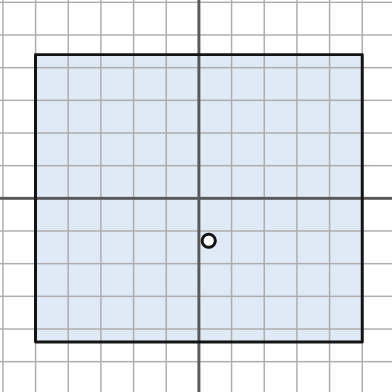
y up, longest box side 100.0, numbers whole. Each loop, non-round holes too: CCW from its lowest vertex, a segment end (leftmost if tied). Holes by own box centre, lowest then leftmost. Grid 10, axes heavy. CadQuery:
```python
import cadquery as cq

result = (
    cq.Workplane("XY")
    .moveTo(-50.0, -44.0)
    .lineTo(50.0, -44.0)
    .lineTo(50.0, 44.0)
    .lineTo(-50.0, 44.0)
    .close()
    .moveTo(3.0, -13.0)
    .circle(2.0)
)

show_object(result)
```